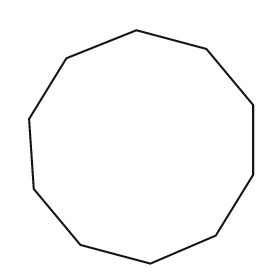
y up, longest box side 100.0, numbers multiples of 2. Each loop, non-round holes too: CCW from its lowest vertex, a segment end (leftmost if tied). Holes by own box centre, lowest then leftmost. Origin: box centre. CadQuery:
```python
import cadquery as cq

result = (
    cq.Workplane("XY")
    .moveTo(4.0, -50.0)
    .lineTo(32.0, -38.0)
    .lineTo(48.0, -12.0)
    .lineTo(48.0, 18.0)
    .lineTo(28.0, 42.0)
    .lineTo(-2.0, 50.0)
    .lineTo(-32.0, 38.0)
    .lineTo(-48.0, 12.0)
    .lineTo(-46.0, -18.0)
    .lineTo(-26.0, -42.0)
    .close()
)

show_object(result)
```